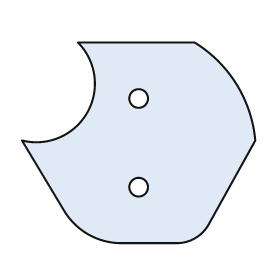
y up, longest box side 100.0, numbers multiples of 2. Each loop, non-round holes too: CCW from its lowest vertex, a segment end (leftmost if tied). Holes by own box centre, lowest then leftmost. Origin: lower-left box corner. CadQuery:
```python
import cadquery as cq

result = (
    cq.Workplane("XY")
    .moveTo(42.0, 0.0)
    .lineTo(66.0, 0.0)
    .threePointArc((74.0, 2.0), (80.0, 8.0))
    .lineTo(100.0, 44.0)
    .threePointArc((92.0, 68.0), (74.0, 86.0))
    .lineTo(24.0, 86.0)
    .threePointArc((28.0, 56.0), (0.0, 44.0))
    .lineTo(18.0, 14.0)
    .threePointArc((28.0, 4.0), (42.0, 0.0))
    .close()
    .moveTo(50.0, 24.0)
    .circle(4.0)
    .moveTo(50.0, 62.0)
    .circle(4.0)
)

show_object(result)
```